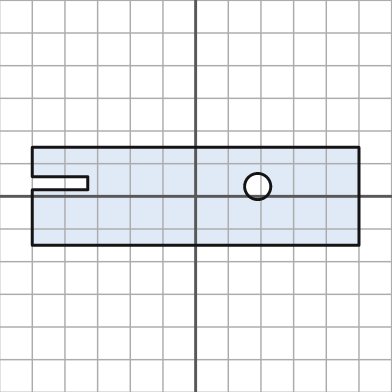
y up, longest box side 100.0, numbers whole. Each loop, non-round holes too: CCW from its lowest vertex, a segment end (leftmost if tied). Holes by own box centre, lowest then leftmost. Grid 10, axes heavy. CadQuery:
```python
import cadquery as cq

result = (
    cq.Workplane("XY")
    .moveTo(-50.0, -15.0)
    .lineTo(50.0, -15.0)
    .lineTo(50.0, 15.0)
    .lineTo(-50.0, 15.0)
    .lineTo(-50.0, 6.0)
    .lineTo(-33.0, 6.0)
    .lineTo(-33.0, 2.0)
    .lineTo(-50.0, 2.0)
    .close()
    .moveTo(19.0, 3.0)
    .circle(4.0)
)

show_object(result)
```